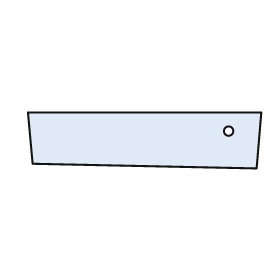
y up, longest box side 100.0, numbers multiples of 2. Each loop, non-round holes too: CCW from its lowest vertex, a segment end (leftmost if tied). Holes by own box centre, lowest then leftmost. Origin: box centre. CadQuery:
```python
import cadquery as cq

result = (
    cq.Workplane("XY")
    .moveTo(48.0, -12.0)
    .lineTo(50.0, 12.0)
    .lineTo(-50.0, 12.0)
    .lineTo(-48.0, -10.0)
    .close()
    .moveTo(36.0, 4.0)
    .circle(2.0)
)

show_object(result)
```